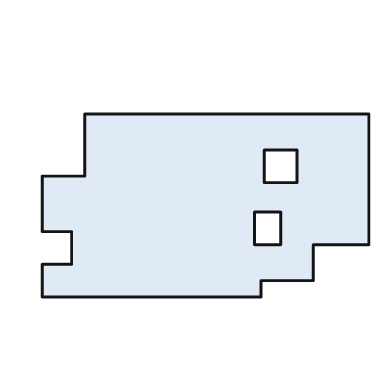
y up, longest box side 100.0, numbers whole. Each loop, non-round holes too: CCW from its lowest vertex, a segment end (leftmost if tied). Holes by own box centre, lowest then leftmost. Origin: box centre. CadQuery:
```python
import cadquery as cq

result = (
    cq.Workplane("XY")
    .moveTo(-50.0, -28.0)
    .lineTo(17.0, -28.0)
    .lineTo(17.0, -23.0)
    .lineTo(33.0, -23.0)
    .lineTo(33.0, -12.0)
    .lineTo(50.0, -12.0)
    .lineTo(50.0, 28.0)
    .lineTo(-37.0, 28.0)
    .lineTo(-37.0, 9.0)
    .lineTo(-50.0, 9.0)
    .lineTo(-50.0, -8.0)
    .lineTo(-41.0, -8.0)
    .lineTo(-41.0, -18.0)
    .lineTo(-50.0, -18.0)
    .close()
    .moveTo(15.0, -12.0)
    .lineTo(23.0, -12.0)
    .lineTo(23.0, -2.0)
    .lineTo(15.0, -2.0)
    .close()
    .moveTo(18.0, 7.0)
    .lineTo(28.0, 7.0)
    .lineTo(28.0, 17.0)
    .lineTo(18.0, 17.0)
    .close()
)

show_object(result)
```